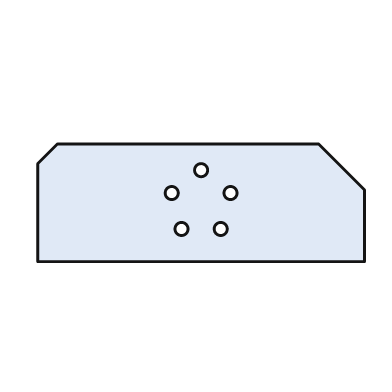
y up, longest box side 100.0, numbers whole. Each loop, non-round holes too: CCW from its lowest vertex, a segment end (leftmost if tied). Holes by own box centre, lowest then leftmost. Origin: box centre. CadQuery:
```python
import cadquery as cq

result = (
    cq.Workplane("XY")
    .moveTo(-50.0, -18.0)
    .lineTo(50.0, -18.0)
    .lineTo(50.0, 4.0)
    .lineTo(36.0, 18.0)
    .lineTo(-44.0, 18.0)
    .lineTo(-50.0, 12.0)
    .close()
    .moveTo(-6.0, -8.0)
    .circle(2.0)
    .moveTo(6.0, -8.0)
    .circle(2.0)
    .moveTo(-9.0, 3.0)
    .circle(2.0)
    .moveTo(9.0, 3.0)
    .circle(2.0)
    .moveTo(0.0, 10.0)
    .circle(2.0)
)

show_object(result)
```